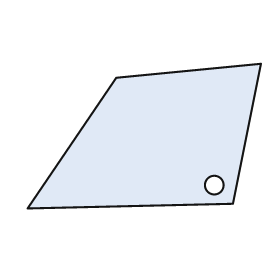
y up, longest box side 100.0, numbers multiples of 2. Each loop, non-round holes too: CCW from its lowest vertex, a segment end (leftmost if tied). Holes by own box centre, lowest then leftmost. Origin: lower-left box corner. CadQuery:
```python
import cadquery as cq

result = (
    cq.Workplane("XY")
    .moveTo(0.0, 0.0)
    .lineTo(88.0, 2.0)
    .lineTo(100.0, 62.0)
    .lineTo(38.0, 56.0)
    .close()
    .moveTo(80.0, 10.0)
    .circle(4.0)
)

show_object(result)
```